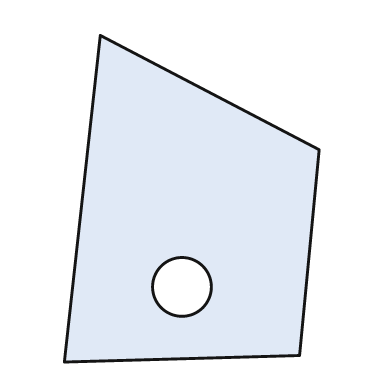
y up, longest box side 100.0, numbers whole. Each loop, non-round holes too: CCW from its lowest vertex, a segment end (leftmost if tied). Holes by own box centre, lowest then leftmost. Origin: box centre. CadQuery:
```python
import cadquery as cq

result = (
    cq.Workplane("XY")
    .moveTo(-39.0, -50.0)
    .lineTo(33.0, -48.0)
    .lineTo(39.0, 15.0)
    .lineTo(-28.0, 50.0)
    .close()
    .moveTo(-3.0, -27.0)
    .circle(9.0)
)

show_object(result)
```